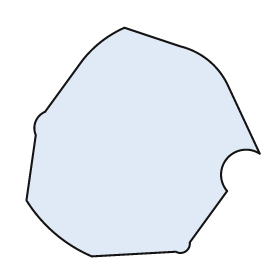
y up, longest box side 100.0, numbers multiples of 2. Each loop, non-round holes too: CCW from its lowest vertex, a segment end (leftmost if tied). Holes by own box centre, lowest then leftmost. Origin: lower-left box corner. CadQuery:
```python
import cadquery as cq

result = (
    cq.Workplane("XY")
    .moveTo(28.0, 0.0)
    .lineTo(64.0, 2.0)
    .threePointArc((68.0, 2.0), (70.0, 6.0))
    .lineTo(86.0, 28.0)
    .threePointArc((86.0, 42.0), (100.0, 44.0))
    .lineTo(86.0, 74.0)
    .threePointArc((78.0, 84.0), (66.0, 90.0))
    .lineTo(42.0, 98.0)
    .threePointArc((32.0, 92.0), (24.0, 84.0))
    .lineTo(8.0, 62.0)
    .threePointArc((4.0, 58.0), (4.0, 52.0))
    .lineTo(0.0, 24.0)
    .threePointArc((12.0, 10.0), (28.0, 0.0))
    .close()
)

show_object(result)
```